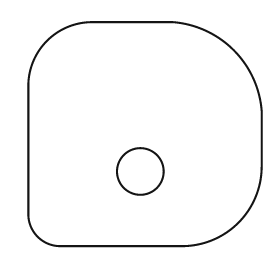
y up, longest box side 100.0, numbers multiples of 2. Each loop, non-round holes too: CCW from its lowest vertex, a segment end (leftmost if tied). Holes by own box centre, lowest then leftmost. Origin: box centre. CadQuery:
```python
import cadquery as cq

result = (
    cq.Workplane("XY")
    .moveTo(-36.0, -48.0)
    .lineTo(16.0, -48.0)
    .threePointArc((40.0, -38.0), (50.0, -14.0))
    .lineTo(50.0, 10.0)
    .threePointArc((38.0, 36.0), (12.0, 48.0))
    .lineTo(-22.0, 48.0)
    .threePointArc((-42.0, 40.0), (-50.0, 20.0))
    .lineTo(-50.0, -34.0)
    .threePointArc((-46.0, -44.0), (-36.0, -48.0))
    .close()
    .moveTo(-2.0, -16.0)
    .circle(10.0)
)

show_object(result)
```